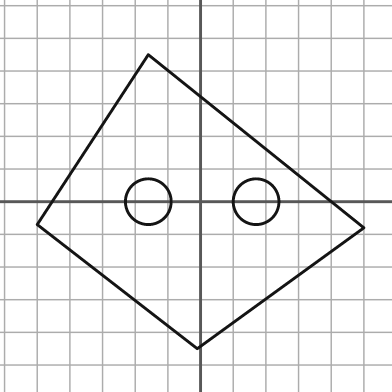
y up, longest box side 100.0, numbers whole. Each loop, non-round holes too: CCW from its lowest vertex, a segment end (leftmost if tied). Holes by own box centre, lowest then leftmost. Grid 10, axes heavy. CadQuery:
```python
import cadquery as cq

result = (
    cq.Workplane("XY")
    .moveTo(-1.0, -45.0)
    .lineTo(50.0, -8.0)
    .lineTo(-16.0, 45.0)
    .lineTo(-50.0, -7.0)
    .close()
    .moveTo(-16.0, 0.0)
    .circle(7.0)
    .moveTo(17.0, 0.0)
    .circle(7.0)
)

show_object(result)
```